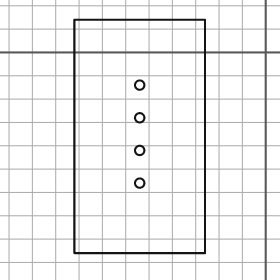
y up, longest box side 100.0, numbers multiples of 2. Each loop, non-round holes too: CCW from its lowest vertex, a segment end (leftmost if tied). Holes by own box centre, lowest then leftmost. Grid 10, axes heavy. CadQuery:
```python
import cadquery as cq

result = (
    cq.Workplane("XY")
    .moveTo(-82.0, -86.0)
    .lineTo(-26.0, -86.0)
    .lineTo(-26.0, 14.0)
    .lineTo(-82.0, 14.0)
    .close()
    .moveTo(-54.0, -56.0)
    .circle(2.0)
    .moveTo(-54.0, -42.0)
    .circle(2.0)
    .moveTo(-54.0, -28.0)
    .circle(2.0)
    .moveTo(-54.0, -14.0)
    .circle(2.0)
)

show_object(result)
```